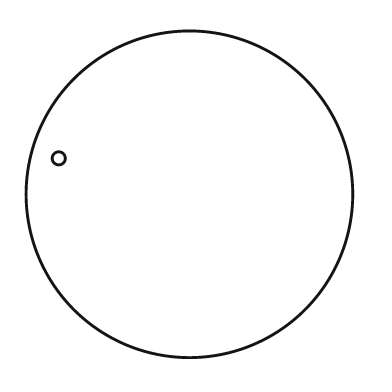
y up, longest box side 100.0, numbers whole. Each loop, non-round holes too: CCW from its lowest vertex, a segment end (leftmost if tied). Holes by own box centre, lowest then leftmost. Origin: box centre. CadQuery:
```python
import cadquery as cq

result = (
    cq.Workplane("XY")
    .moveTo(0.0, 0.0)
    .circle(50.0)
    .moveTo(-40.0, 11.0)
    .circle(2.0)
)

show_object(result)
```